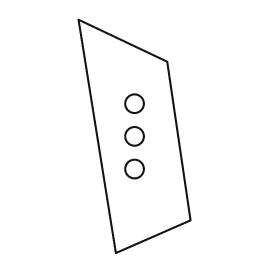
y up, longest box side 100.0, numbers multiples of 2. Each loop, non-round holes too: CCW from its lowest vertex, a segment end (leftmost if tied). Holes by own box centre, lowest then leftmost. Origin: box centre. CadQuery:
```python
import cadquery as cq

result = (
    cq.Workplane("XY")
    .moveTo(-8.0, -50.0)
    .lineTo(24.0, -36.0)
    .lineTo(14.0, 32.0)
    .lineTo(-24.0, 50.0)
    .close()
    .moveTo(0.0, -14.0)
    .circle(4.0)
    .moveTo(0.0, 0.0)
    .circle(4.0)
    .moveTo(0.0, 14.0)
    .circle(4.0)
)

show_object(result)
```